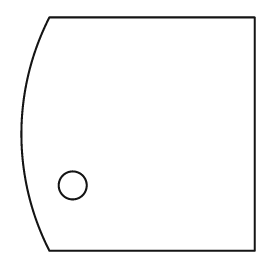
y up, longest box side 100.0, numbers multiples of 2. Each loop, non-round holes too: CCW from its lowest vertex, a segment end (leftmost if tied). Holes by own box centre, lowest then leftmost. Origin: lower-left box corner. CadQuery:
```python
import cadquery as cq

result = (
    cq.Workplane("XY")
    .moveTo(12.0, 0.0)
    .lineTo(100.0, 0.0)
    .lineTo(100.0, 100.0)
    .lineTo(12.0, 100.0)
    .threePointArc((0.0, 50.0), (12.0, 0.0))
    .close()
    .moveTo(22.0, 28.0)
    .circle(6.0)
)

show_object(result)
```